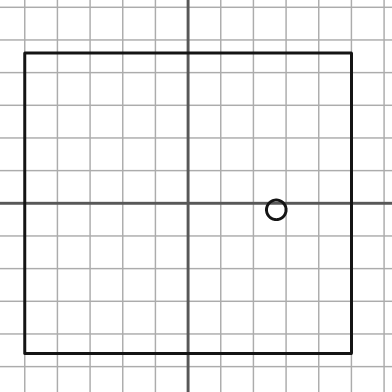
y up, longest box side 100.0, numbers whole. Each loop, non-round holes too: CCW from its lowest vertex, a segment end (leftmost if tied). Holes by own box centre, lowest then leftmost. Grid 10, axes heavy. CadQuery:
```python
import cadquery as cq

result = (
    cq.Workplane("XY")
    .moveTo(-50.0, -46.0)
    .lineTo(50.0, -46.0)
    .lineTo(50.0, 46.0)
    .lineTo(-50.0, 46.0)
    .close()
    .moveTo(27.0, -2.0)
    .circle(3.0)
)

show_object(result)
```